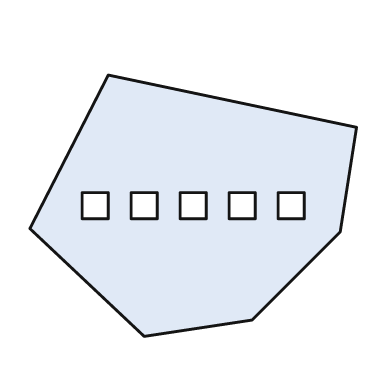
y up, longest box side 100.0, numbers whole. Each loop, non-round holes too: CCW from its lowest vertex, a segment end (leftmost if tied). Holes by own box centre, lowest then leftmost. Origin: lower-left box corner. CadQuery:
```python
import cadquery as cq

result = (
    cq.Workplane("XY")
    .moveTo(35.0, 0.0)
    .lineTo(68.0, 5.0)
    .lineTo(95.0, 32.0)
    .lineTo(100.0, 64.0)
    .lineTo(24.0, 80.0)
    .lineTo(0.0, 33.0)
    .close()
    .moveTo(16.0, 36.0)
    .lineTo(24.0, 36.0)
    .lineTo(24.0, 44.0)
    .lineTo(16.0, 44.0)
    .close()
    .moveTo(31.0, 36.0)
    .lineTo(39.0, 36.0)
    .lineTo(39.0, 44.0)
    .lineTo(31.0, 44.0)
    .close()
    .moveTo(46.0, 36.0)
    .lineTo(54.0, 36.0)
    .lineTo(54.0, 44.0)
    .lineTo(46.0, 44.0)
    .close()
    .moveTo(61.0, 36.0)
    .lineTo(69.0, 36.0)
    .lineTo(69.0, 44.0)
    .lineTo(61.0, 44.0)
    .close()
    .moveTo(76.0, 36.0)
    .lineTo(84.0, 36.0)
    .lineTo(84.0, 44.0)
    .lineTo(76.0, 44.0)
    .close()
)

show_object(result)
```